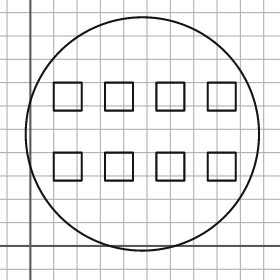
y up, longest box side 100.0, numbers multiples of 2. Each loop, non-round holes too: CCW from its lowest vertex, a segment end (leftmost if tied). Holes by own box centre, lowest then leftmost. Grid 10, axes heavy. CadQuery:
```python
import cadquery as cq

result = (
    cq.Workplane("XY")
    .moveTo(48.0, 48.0)
    .circle(50.0)
    .moveTo(10.0, 28.0)
    .lineTo(22.0, 28.0)
    .lineTo(22.0, 40.0)
    .lineTo(10.0, 40.0)
    .close()
    .moveTo(32.0, 28.0)
    .lineTo(44.0, 28.0)
    .lineTo(44.0, 40.0)
    .lineTo(32.0, 40.0)
    .close()
    .moveTo(54.0, 28.0)
    .lineTo(66.0, 28.0)
    .lineTo(66.0, 40.0)
    .lineTo(54.0, 40.0)
    .close()
    .moveTo(76.0, 28.0)
    .lineTo(88.0, 28.0)
    .lineTo(88.0, 40.0)
    .lineTo(76.0, 40.0)
    .close()
    .moveTo(10.0, 58.0)
    .lineTo(22.0, 58.0)
    .lineTo(22.0, 70.0)
    .lineTo(10.0, 70.0)
    .close()
    .moveTo(32.0, 58.0)
    .lineTo(44.0, 58.0)
    .lineTo(44.0, 70.0)
    .lineTo(32.0, 70.0)
    .close()
    .moveTo(54.0, 58.0)
    .lineTo(66.0, 58.0)
    .lineTo(66.0, 70.0)
    .lineTo(54.0, 70.0)
    .close()
    .moveTo(76.0, 58.0)
    .lineTo(88.0, 58.0)
    .lineTo(88.0, 70.0)
    .lineTo(76.0, 70.0)
    .close()
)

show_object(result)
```